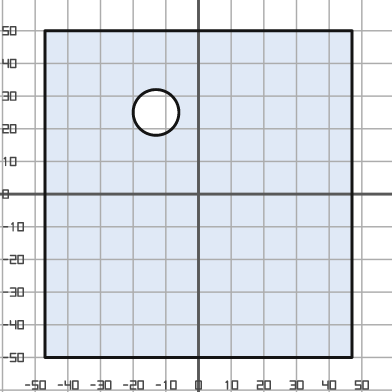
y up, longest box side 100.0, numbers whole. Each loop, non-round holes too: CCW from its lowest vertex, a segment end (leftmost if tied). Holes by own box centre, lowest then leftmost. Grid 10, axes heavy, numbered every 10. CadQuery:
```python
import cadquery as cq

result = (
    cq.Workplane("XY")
    .moveTo(-47.0, -50.0)
    .lineTo(47.0, -50.0)
    .lineTo(47.0, 50.0)
    .lineTo(-47.0, 50.0)
    .close()
    .moveTo(-13.0, 25.0)
    .circle(7.0)
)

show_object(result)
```